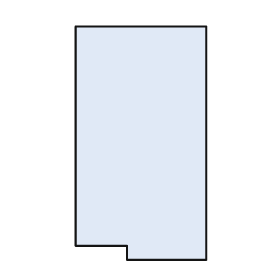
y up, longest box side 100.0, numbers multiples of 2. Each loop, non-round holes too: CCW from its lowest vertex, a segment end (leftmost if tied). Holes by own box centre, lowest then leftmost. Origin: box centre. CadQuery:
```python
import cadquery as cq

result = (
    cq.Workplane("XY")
    .moveTo(-6.0, -50.0)
    .lineTo(28.0, -50.0)
    .lineTo(28.0, 50.0)
    .lineTo(-28.0, 50.0)
    .lineTo(-28.0, -44.0)
    .lineTo(-6.0, -44.0)
    .close()
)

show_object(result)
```